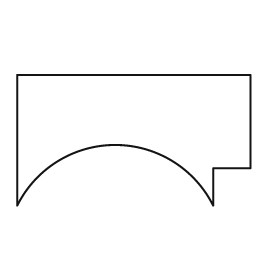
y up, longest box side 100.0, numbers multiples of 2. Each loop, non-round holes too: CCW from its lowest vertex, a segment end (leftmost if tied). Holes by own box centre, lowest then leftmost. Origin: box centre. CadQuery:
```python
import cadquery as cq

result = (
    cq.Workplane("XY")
    .moveTo(-50.0, -28.0)
    .threePointArc((-8.0, -2.0), (34.0, -28.0))
    .lineTo(34.0, -12.0)
    .lineTo(50.0, -12.0)
    .lineTo(50.0, 28.0)
    .lineTo(-50.0, 28.0)
    .close()
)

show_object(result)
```